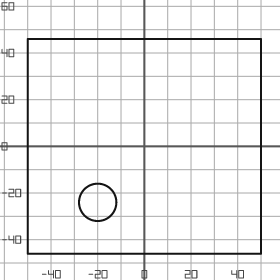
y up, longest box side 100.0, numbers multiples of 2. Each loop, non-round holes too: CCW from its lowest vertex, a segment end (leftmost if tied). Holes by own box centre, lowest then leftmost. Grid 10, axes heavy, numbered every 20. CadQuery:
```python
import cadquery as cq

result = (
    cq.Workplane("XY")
    .moveTo(-50.0, -46.0)
    .lineTo(50.0, -46.0)
    .lineTo(50.0, 46.0)
    .lineTo(-50.0, 46.0)
    .close()
    .moveTo(-20.0, -24.0)
    .circle(8.0)
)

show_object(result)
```